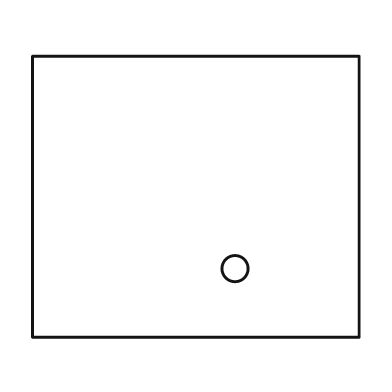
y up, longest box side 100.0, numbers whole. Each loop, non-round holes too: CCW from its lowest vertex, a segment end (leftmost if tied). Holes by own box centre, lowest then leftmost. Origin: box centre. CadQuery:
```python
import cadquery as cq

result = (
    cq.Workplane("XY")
    .moveTo(-50.0, -43.0)
    .lineTo(50.0, -43.0)
    .lineTo(50.0, 43.0)
    .lineTo(-50.0, 43.0)
    .close()
    .moveTo(12.0, -22.0)
    .circle(4.0)
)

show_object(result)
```